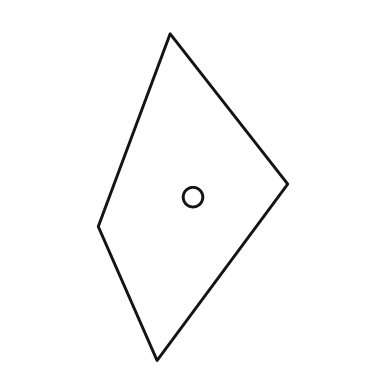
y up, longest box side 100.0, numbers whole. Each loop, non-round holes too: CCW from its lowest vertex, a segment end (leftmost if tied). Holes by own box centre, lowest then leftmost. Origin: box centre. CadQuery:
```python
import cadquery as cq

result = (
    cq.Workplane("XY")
    .moveTo(-11.0, -50.0)
    .lineTo(29.0, 4.0)
    .lineTo(-7.0, 50.0)
    .lineTo(-29.0, -9.0)
    .close()
    .moveTo(0.0, 0.0)
    .circle(3.0)
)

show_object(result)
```